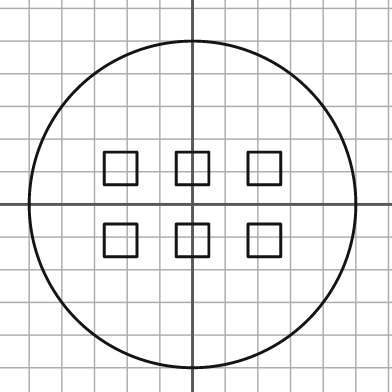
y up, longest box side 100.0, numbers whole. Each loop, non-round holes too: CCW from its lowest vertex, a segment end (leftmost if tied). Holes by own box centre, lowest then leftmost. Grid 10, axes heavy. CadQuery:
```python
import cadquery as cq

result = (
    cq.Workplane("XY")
    .moveTo(0.0, 0.0)
    .circle(50.0)
    .moveTo(-27.0, -16.0)
    .lineTo(-17.0, -16.0)
    .lineTo(-17.0, -6.0)
    .lineTo(-27.0, -6.0)
    .close()
    .moveTo(-5.0, -16.0)
    .lineTo(5.0, -16.0)
    .lineTo(5.0, -6.0)
    .lineTo(-5.0, -6.0)
    .close()
    .moveTo(17.0, -16.0)
    .lineTo(27.0, -16.0)
    .lineTo(27.0, -6.0)
    .lineTo(17.0, -6.0)
    .close()
    .moveTo(-27.0, 6.0)
    .lineTo(-17.0, 6.0)
    .lineTo(-17.0, 16.0)
    .lineTo(-27.0, 16.0)
    .close()
    .moveTo(-5.0, 6.0)
    .lineTo(5.0, 6.0)
    .lineTo(5.0, 16.0)
    .lineTo(-5.0, 16.0)
    .close()
    .moveTo(17.0, 6.0)
    .lineTo(27.0, 6.0)
    .lineTo(27.0, 16.0)
    .lineTo(17.0, 16.0)
    .close()
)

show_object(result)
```